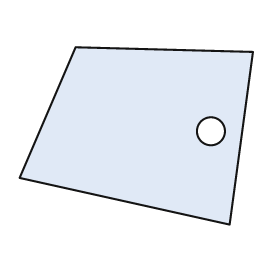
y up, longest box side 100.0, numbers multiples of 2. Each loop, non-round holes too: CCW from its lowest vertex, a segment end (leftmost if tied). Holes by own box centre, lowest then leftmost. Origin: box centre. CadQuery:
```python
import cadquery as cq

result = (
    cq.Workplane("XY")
    .moveTo(40.0, -38.0)
    .lineTo(50.0, 36.0)
    .lineTo(-26.0, 38.0)
    .lineTo(-50.0, -18.0)
    .close()
    .moveTo(32.0, 2.0)
    .circle(6.0)
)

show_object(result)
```